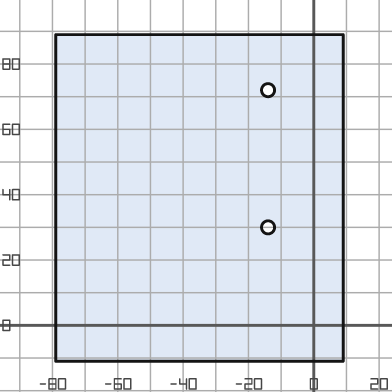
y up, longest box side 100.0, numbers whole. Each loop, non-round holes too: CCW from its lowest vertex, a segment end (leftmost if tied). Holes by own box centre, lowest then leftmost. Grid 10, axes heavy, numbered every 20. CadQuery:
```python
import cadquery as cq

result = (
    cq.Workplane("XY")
    .moveTo(-79.0, -11.0)
    .lineTo(9.0, -11.0)
    .lineTo(9.0, 89.0)
    .lineTo(-79.0, 89.0)
    .close()
    .moveTo(-14.0, 30.0)
    .circle(2.0)
    .moveTo(-14.0, 72.0)
    .circle(2.0)
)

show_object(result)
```